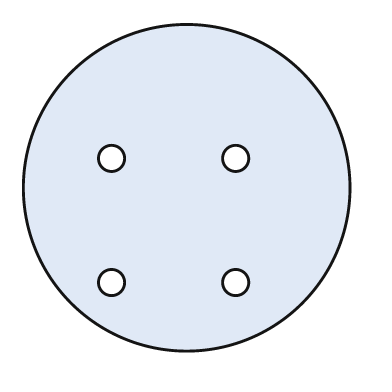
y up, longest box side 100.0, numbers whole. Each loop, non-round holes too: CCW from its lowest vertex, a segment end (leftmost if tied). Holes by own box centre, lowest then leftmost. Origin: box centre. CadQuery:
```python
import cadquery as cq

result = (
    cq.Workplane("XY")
    .moveTo(0.0, 0.0)
    .circle(50.0)
    .moveTo(-23.0, -29.0)
    .circle(4.0)
    .moveTo(15.0, -29.0)
    .circle(4.0)
    .moveTo(-23.0, 9.0)
    .circle(4.0)
    .moveTo(15.0, 9.0)
    .circle(4.0)
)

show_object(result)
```